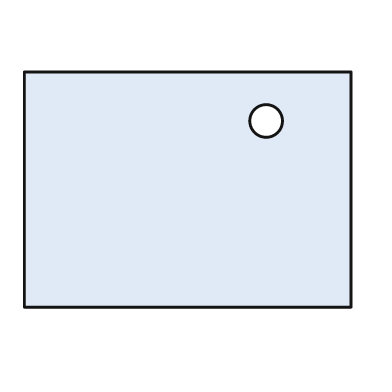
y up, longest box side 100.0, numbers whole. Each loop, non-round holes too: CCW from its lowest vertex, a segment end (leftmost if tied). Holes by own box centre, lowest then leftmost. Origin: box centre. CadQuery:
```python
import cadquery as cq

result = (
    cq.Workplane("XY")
    .moveTo(-50.0, -36.0)
    .lineTo(50.0, -36.0)
    .lineTo(50.0, 36.0)
    .lineTo(-50.0, 36.0)
    .close()
    .moveTo(24.0, 21.0)
    .circle(5.0)
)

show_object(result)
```